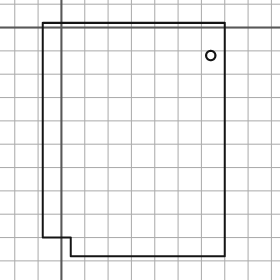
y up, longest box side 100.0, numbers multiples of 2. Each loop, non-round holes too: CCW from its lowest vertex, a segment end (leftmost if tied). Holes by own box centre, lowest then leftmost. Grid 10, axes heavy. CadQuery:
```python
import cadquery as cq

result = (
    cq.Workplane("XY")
    .moveTo(4.0, -98.0)
    .lineTo(70.0, -98.0)
    .lineTo(70.0, 2.0)
    .lineTo(-8.0, 2.0)
    .lineTo(-8.0, -90.0)
    .lineTo(4.0, -90.0)
    .close()
    .moveTo(64.0, -12.0)
    .circle(2.0)
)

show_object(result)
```